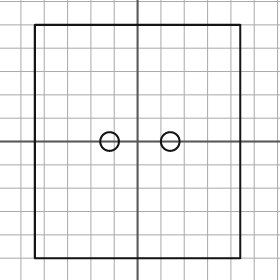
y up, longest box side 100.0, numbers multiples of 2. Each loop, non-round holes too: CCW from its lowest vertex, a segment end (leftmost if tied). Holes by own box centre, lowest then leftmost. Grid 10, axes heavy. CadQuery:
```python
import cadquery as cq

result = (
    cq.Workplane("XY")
    .moveTo(-44.0, -50.0)
    .lineTo(44.0, -50.0)
    .lineTo(44.0, 50.0)
    .lineTo(-44.0, 50.0)
    .close()
    .moveTo(-12.0, 0.0)
    .circle(4.0)
    .moveTo(14.0, 0.0)
    .circle(4.0)
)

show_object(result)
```